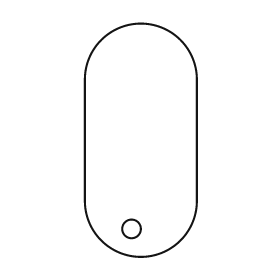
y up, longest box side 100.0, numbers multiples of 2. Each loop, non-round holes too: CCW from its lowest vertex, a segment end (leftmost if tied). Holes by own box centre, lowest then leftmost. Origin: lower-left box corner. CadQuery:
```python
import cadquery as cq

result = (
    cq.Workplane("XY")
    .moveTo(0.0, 24.0)
    .threePointArc((24.0, 0.0), (48.0, 24.0))
    .lineTo(48.0, 76.0)
    .threePointArc((24.0, 100.0), (0.0, 76.0))
    .close()
    .moveTo(20.0, 12.0)
    .circle(4.0)
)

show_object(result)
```